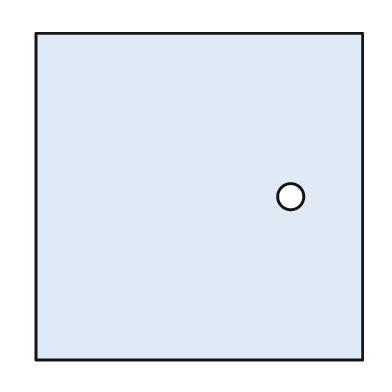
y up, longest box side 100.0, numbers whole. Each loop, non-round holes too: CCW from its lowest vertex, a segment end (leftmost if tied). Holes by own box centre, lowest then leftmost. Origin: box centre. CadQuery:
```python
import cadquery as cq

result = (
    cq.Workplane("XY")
    .moveTo(-50.0, -50.0)
    .lineTo(50.0, -50.0)
    .lineTo(50.0, 50.0)
    .lineTo(-50.0, 50.0)
    .close()
    .moveTo(28.0, 0.0)
    .circle(4.0)
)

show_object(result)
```